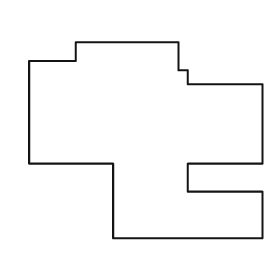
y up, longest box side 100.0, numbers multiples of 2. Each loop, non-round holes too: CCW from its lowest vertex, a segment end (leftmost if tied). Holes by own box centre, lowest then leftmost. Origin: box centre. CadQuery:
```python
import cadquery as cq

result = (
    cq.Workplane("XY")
    .moveTo(-14.0, -42.0)
    .lineTo(50.0, -42.0)
    .lineTo(50.0, -22.0)
    .lineTo(18.0, -22.0)
    .lineTo(18.0, -10.0)
    .lineTo(50.0, -10.0)
    .lineTo(50.0, 24.0)
    .lineTo(18.0, 24.0)
    .lineTo(18.0, 30.0)
    .lineTo(14.0, 30.0)
    .lineTo(14.0, 42.0)
    .lineTo(-30.0, 42.0)
    .lineTo(-30.0, 34.0)
    .lineTo(-50.0, 34.0)
    .lineTo(-50.0, -10.0)
    .lineTo(-14.0, -10.0)
    .close()
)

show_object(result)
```